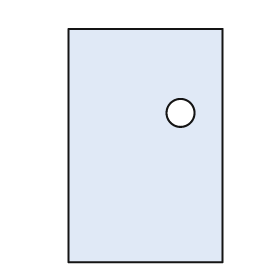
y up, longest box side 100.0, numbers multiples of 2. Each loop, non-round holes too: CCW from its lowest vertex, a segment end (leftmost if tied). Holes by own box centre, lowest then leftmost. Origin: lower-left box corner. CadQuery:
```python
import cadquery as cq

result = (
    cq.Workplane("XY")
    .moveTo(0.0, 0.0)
    .lineTo(66.0, 0.0)
    .lineTo(66.0, 100.0)
    .lineTo(0.0, 100.0)
    .close()
    .moveTo(48.0, 64.0)
    .circle(6.0)
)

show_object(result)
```